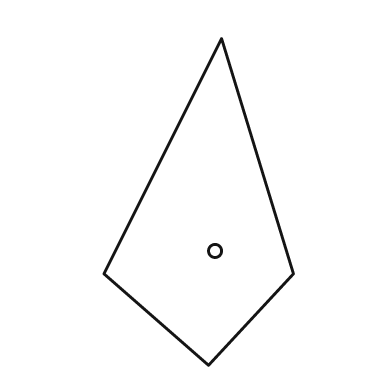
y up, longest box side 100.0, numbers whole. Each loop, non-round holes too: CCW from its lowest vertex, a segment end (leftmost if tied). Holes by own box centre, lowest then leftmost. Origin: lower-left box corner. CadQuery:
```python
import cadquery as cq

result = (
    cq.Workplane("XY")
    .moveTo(32.0, 0.0)
    .lineTo(58.0, 28.0)
    .lineTo(36.0, 100.0)
    .lineTo(0.0, 28.0)
    .close()
    .moveTo(34.0, 35.0)
    .circle(2.0)
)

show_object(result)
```